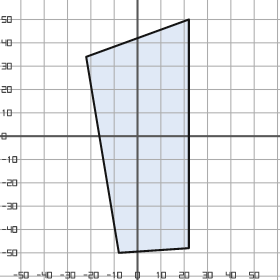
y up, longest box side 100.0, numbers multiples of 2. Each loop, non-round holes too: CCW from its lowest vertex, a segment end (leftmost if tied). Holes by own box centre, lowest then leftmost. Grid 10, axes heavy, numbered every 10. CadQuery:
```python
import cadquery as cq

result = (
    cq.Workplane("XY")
    .moveTo(-8.0, -50.0)
    .lineTo(22.0, -48.0)
    .lineTo(22.0, 50.0)
    .lineTo(-22.0, 34.0)
    .close()
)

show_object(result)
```